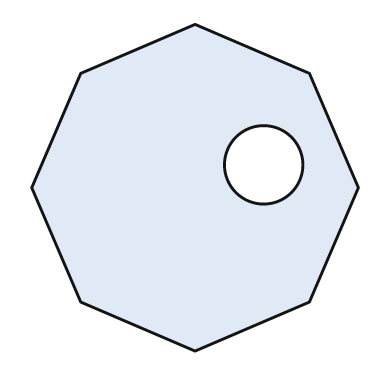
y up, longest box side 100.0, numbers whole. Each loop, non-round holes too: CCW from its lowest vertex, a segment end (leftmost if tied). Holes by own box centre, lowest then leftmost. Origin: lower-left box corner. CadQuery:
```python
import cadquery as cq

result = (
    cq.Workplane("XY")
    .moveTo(50.0, 0.0)
    .lineTo(85.0, 15.0)
    .lineTo(100.0, 50.0)
    .lineTo(85.0, 85.0)
    .lineTo(50.0, 100.0)
    .lineTo(15.0, 85.0)
    .lineTo(0.0, 50.0)
    .lineTo(15.0, 15.0)
    .close()
    .moveTo(71.0, 57.0)
    .circle(12.0)
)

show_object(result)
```